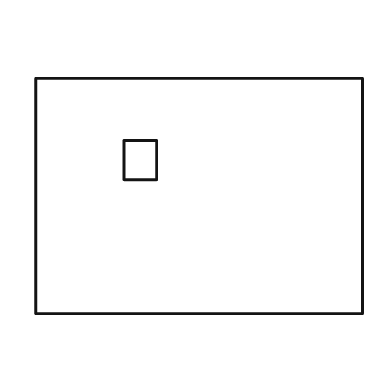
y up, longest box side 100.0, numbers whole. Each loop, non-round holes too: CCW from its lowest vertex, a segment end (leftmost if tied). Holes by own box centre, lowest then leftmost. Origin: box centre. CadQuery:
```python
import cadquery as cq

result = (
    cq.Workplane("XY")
    .moveTo(-50.0, -36.0)
    .lineTo(50.0, -36.0)
    .lineTo(50.0, 36.0)
    .lineTo(-50.0, 36.0)
    .close()
    .moveTo(-23.0, 5.0)
    .lineTo(-13.0, 5.0)
    .lineTo(-13.0, 17.0)
    .lineTo(-23.0, 17.0)
    .close()
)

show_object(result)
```